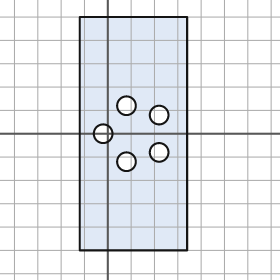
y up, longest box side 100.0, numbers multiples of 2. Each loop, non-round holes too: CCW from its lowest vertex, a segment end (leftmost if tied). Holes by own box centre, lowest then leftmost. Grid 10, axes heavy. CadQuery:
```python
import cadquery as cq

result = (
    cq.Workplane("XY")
    .moveTo(-12.0, -50.0)
    .lineTo(34.0, -50.0)
    .lineTo(34.0, 50.0)
    .lineTo(-12.0, 50.0)
    .close()
    .moveTo(8.0, -12.0)
    .circle(4.0)
    .moveTo(22.0, -8.0)
    .circle(4.0)
    .moveTo(-2.0, 0.0)
    .circle(4.0)
    .moveTo(22.0, 8.0)
    .circle(4.0)
    .moveTo(8.0, 12.0)
    .circle(4.0)
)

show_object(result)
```